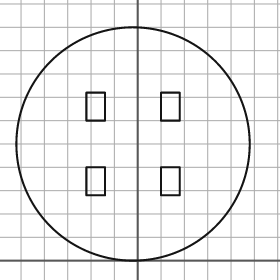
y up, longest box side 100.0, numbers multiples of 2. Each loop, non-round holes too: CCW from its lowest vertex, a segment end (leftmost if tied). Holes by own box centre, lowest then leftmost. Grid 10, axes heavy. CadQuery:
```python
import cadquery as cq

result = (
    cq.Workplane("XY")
    .moveTo(-2.0, 50.0)
    .circle(50.0)
    .moveTo(-22.0, 28.0)
    .lineTo(-14.0, 28.0)
    .lineTo(-14.0, 40.0)
    .lineTo(-22.0, 40.0)
    .close()
    .moveTo(10.0, 28.0)
    .lineTo(18.0, 28.0)
    .lineTo(18.0, 40.0)
    .lineTo(10.0, 40.0)
    .close()
    .moveTo(-22.0, 60.0)
    .lineTo(-14.0, 60.0)
    .lineTo(-14.0, 72.0)
    .lineTo(-22.0, 72.0)
    .close()
    .moveTo(10.0, 60.0)
    .lineTo(18.0, 60.0)
    .lineTo(18.0, 72.0)
    .lineTo(10.0, 72.0)
    .close()
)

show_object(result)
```